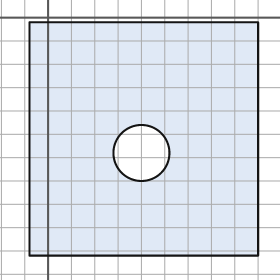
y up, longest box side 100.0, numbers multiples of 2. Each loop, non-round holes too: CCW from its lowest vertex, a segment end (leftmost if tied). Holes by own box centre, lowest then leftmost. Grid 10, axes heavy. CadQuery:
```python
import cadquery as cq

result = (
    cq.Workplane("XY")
    .moveTo(-8.0, -102.0)
    .lineTo(90.0, -102.0)
    .lineTo(90.0, -2.0)
    .lineTo(-8.0, -2.0)
    .close()
    .moveTo(40.0, -58.0)
    .circle(12.0)
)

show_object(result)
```